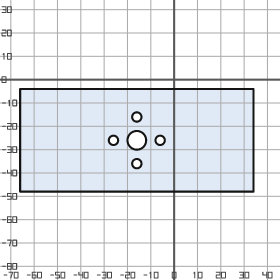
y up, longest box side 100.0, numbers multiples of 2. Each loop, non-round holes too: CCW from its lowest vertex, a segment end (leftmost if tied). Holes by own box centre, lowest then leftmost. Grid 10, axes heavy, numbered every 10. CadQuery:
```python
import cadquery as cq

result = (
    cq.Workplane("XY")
    .moveTo(-66.0, -48.0)
    .lineTo(34.0, -48.0)
    .lineTo(34.0, -4.0)
    .lineTo(-66.0, -4.0)
    .close()
    .moveTo(-16.0, -36.0)
    .circle(2.0)
    .moveTo(-26.0, -26.0)
    .circle(2.0)
    .moveTo(-16.0, -26.0)
    .circle(4.0)
    .moveTo(-6.0, -26.0)
    .circle(2.0)
    .moveTo(-16.0, -16.0)
    .circle(2.0)
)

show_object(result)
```